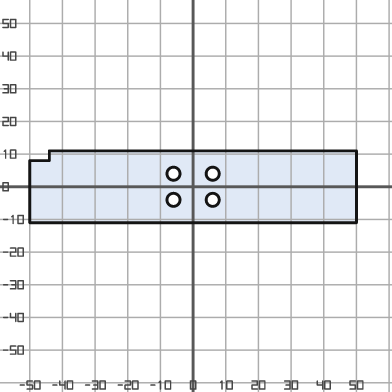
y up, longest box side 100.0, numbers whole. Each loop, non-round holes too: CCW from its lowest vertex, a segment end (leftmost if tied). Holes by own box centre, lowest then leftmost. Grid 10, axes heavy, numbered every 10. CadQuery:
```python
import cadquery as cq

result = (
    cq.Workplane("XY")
    .moveTo(-50.0, -11.0)
    .lineTo(50.0, -11.0)
    .lineTo(50.0, 11.0)
    .lineTo(-44.0, 11.0)
    .lineTo(-44.0, 8.0)
    .lineTo(-50.0, 8.0)
    .close()
    .moveTo(-6.0, -4.0)
    .circle(2.0)
    .moveTo(6.0, -4.0)
    .circle(2.0)
    .moveTo(-6.0, 4.0)
    .circle(2.0)
    .moveTo(6.0, 4.0)
    .circle(2.0)
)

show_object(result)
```